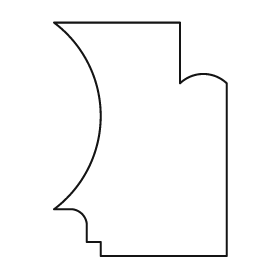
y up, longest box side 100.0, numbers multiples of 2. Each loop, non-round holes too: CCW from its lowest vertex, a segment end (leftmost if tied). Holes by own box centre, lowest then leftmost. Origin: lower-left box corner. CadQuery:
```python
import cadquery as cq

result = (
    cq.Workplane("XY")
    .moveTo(20.0, 0.0)
    .lineTo(74.0, 0.0)
    .lineTo(74.0, 74.0)
    .threePointArc((64.0, 78.0), (54.0, 74.0))
    .lineTo(54.0, 100.0)
    .lineTo(0.0, 100.0)
    .threePointArc((20.0, 60.0), (0.0, 20.0))
    .lineTo(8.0, 20.0)
    .threePointArc((12.0, 18.0), (14.0, 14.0))
    .lineTo(14.0, 6.0)
    .lineTo(20.0, 6.0)
    .close()
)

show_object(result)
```